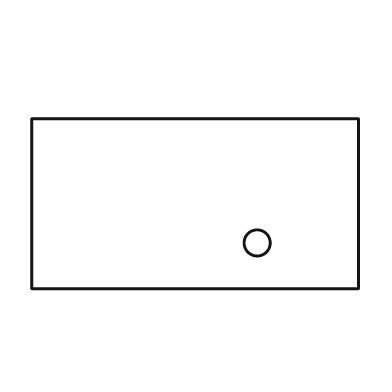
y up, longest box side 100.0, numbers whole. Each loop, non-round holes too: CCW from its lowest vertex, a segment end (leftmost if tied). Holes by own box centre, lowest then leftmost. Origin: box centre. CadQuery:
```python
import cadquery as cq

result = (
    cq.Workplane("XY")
    .moveTo(-50.0, -26.0)
    .lineTo(50.0, -26.0)
    .lineTo(50.0, 26.0)
    .lineTo(-50.0, 26.0)
    .close()
    .moveTo(19.0, -12.0)
    .circle(4.0)
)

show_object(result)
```